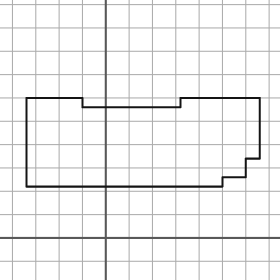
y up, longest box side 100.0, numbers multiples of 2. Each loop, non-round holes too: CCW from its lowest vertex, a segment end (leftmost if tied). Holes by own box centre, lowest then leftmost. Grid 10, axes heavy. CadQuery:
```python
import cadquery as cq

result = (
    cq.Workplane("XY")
    .moveTo(-34.0, 22.0)
    .lineTo(50.0, 22.0)
    .lineTo(50.0, 26.0)
    .lineTo(60.0, 26.0)
    .lineTo(60.0, 34.0)
    .lineTo(66.0, 34.0)
    .lineTo(66.0, 60.0)
    .lineTo(32.0, 60.0)
    .lineTo(32.0, 56.0)
    .lineTo(-10.0, 56.0)
    .lineTo(-10.0, 60.0)
    .lineTo(-34.0, 60.0)
    .close()
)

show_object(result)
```